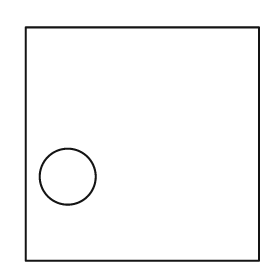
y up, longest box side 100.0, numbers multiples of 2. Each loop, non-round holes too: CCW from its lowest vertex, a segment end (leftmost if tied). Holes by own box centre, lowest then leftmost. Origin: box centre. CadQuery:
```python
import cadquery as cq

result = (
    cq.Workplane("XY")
    .moveTo(-50.0, -50.0)
    .lineTo(50.0, -50.0)
    .lineTo(50.0, 50.0)
    .lineTo(-50.0, 50.0)
    .close()
    .moveTo(-32.0, -14.0)
    .circle(12.0)
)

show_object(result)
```